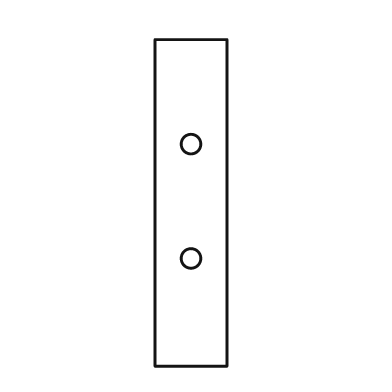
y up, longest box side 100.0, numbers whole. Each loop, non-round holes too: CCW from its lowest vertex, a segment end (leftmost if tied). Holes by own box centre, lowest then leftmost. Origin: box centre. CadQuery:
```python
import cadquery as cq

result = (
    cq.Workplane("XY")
    .moveTo(-11.0, -50.0)
    .lineTo(11.0, -50.0)
    .lineTo(11.0, 50.0)
    .lineTo(-11.0, 50.0)
    .close()
    .moveTo(0.0, -17.0)
    .circle(3.0)
    .moveTo(0.0, 18.0)
    .circle(3.0)
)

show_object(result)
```